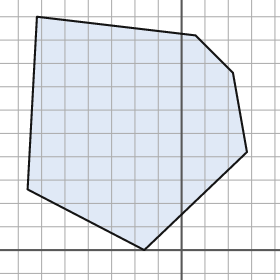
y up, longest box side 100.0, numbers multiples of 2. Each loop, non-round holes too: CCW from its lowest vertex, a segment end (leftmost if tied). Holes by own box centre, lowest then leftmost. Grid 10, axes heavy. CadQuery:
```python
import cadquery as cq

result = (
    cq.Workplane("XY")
    .moveTo(-16.0, 0.0)
    .lineTo(28.0, 42.0)
    .lineTo(22.0, 76.0)
    .lineTo(6.0, 92.0)
    .lineTo(-62.0, 100.0)
    .lineTo(-66.0, 26.0)
    .close()
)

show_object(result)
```